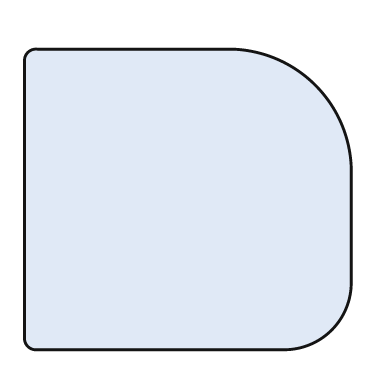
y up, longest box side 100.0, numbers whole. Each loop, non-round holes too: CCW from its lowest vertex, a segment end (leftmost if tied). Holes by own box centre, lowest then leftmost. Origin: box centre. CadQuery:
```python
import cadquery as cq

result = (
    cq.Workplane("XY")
    .moveTo(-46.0, -46.0)
    .lineTo(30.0, -46.0)
    .threePointArc((44.0, -40.0), (50.0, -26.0))
    .lineTo(50.0, 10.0)
    .threePointArc((39.0, 35.0), (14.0, 46.0))
    .lineTo(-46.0, 46.0)
    .threePointArc((-49.0, 45.0), (-50.0, 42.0))
    .lineTo(-50.0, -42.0)
    .threePointArc((-49.0, -45.0), (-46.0, -46.0))
    .close()
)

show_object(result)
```